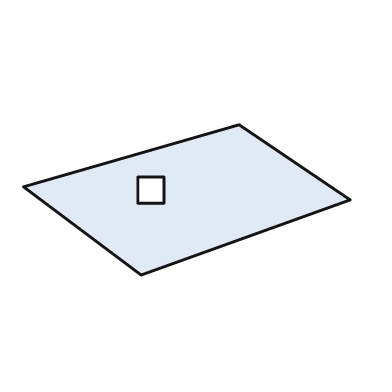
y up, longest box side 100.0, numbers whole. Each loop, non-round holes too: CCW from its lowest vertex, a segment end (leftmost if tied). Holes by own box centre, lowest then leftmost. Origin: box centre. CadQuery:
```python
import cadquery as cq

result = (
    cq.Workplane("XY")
    .moveTo(-14.0, -23.0)
    .lineTo(50.0, 0.0)
    .lineTo(16.0, 23.0)
    .lineTo(-50.0, 4.0)
    .close()
    .moveTo(-15.0, -1.0)
    .lineTo(-7.0, -1.0)
    .lineTo(-7.0, 7.0)
    .lineTo(-15.0, 7.0)
    .close()
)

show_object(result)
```